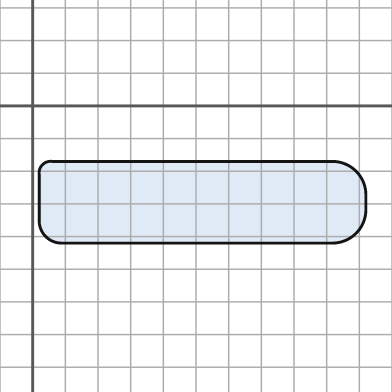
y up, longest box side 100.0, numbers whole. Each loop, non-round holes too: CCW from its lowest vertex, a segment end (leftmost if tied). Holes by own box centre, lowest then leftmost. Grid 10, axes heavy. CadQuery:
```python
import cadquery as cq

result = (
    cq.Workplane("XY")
    .moveTo(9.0, -42.0)
    .lineTo(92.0, -42.0)
    .threePointArc((99.0, -39.0), (102.0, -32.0))
    .lineTo(102.0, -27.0)
    .threePointArc((99.0, -20.0), (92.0, -17.0))
    .lineTo(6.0, -17.0)
    .threePointArc((3.0, -18.0), (2.0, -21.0))
    .lineTo(2.0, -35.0)
    .threePointArc((4.0, -40.0), (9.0, -42.0))
    .close()
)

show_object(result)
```